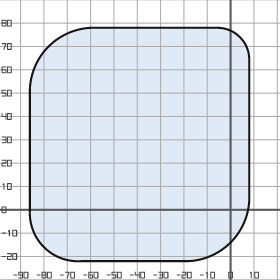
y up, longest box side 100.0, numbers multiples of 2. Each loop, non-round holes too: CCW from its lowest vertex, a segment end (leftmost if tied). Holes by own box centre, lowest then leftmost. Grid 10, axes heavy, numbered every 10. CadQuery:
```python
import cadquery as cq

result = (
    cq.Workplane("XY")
    .moveTo(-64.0, -22.0)
    .lineTo(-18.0, -22.0)
    .threePointArc((0.0, -14.0), (8.0, 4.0))
    .lineTo(8.0, 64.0)
    .threePointArc((4.0, 74.0), (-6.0, 78.0))
    .lineTo(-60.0, 78.0)
    .threePointArc((-78.0, 70.0), (-86.0, 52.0))
    .lineTo(-86.0, 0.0)
    .threePointArc((-80.0, -16.0), (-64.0, -22.0))
    .close()
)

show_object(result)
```